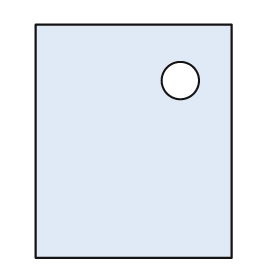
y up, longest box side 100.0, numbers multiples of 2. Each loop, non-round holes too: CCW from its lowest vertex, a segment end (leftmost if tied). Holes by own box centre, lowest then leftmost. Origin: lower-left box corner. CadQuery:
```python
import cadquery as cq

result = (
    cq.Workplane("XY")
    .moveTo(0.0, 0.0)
    .lineTo(84.0, 0.0)
    .lineTo(84.0, 100.0)
    .lineTo(0.0, 100.0)
    .close()
    .moveTo(62.0, 76.0)
    .circle(8.0)
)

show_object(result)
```